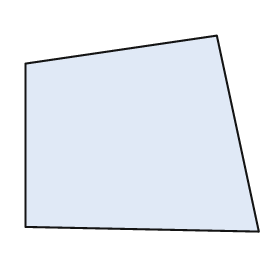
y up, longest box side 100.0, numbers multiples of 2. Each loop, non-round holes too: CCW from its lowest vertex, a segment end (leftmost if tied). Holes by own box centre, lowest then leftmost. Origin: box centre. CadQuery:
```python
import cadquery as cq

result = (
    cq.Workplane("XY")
    .moveTo(50.0, -42.0)
    .lineTo(32.0, 42.0)
    .lineTo(-50.0, 30.0)
    .lineTo(-50.0, -40.0)
    .close()
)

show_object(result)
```